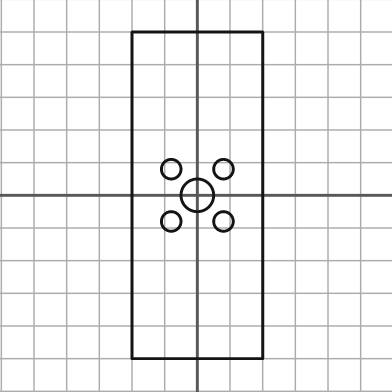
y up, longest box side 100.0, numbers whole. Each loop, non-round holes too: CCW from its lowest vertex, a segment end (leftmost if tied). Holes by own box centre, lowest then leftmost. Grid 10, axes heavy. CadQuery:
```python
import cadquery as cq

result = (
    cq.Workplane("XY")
    .moveTo(-20.0, -50.0)
    .lineTo(20.0, -50.0)
    .lineTo(20.0, 50.0)
    .lineTo(-20.0, 50.0)
    .close()
    .moveTo(-8.0, -8.0)
    .circle(3.0)
    .moveTo(8.0, -8.0)
    .circle(3.0)
    .moveTo(0.0, 0.0)
    .circle(5.0)
    .moveTo(-8.0, 8.0)
    .circle(3.0)
    .moveTo(8.0, 8.0)
    .circle(3.0)
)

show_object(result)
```